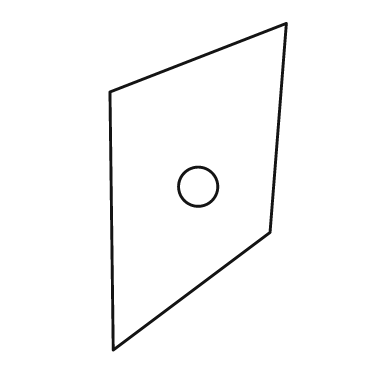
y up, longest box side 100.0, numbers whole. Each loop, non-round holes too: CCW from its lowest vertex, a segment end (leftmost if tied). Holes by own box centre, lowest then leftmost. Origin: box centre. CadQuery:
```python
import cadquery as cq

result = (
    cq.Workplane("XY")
    .moveTo(-26.0, -50.0)
    .lineTo(22.0, -14.0)
    .lineTo(27.0, 50.0)
    .lineTo(-27.0, 29.0)
    .close()
    .moveTo(0.0, 0.0)
    .circle(6.0)
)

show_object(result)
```